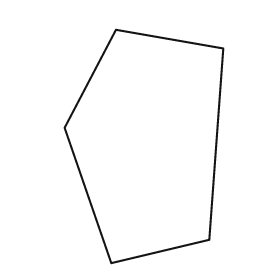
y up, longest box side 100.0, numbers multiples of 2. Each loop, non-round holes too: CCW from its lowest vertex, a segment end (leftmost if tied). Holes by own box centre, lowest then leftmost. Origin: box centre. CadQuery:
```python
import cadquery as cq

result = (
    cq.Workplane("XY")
    .moveTo(-14.0, -50.0)
    .lineTo(28.0, -40.0)
    .lineTo(34.0, 42.0)
    .lineTo(-12.0, 50.0)
    .lineTo(-34.0, 8.0)
    .close()
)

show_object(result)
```